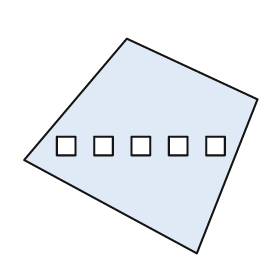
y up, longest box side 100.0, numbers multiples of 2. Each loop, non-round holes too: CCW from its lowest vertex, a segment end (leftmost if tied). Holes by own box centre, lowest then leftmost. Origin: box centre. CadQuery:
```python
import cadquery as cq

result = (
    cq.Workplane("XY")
    .moveTo(24.0, -46.0)
    .lineTo(50.0, 20.0)
    .lineTo(-6.0, 46.0)
    .lineTo(-50.0, -6.0)
    .close()
    .moveTo(-36.0, -4.0)
    .lineTo(-28.0, -4.0)
    .lineTo(-28.0, 4.0)
    .lineTo(-36.0, 4.0)
    .close()
    .moveTo(-20.0, -4.0)
    .lineTo(-12.0, -4.0)
    .lineTo(-12.0, 4.0)
    .lineTo(-20.0, 4.0)
    .close()
    .moveTo(-4.0, -4.0)
    .lineTo(4.0, -4.0)
    .lineTo(4.0, 4.0)
    .lineTo(-4.0, 4.0)
    .close()
    .moveTo(12.0, -4.0)
    .lineTo(20.0, -4.0)
    .lineTo(20.0, 4.0)
    .lineTo(12.0, 4.0)
    .close()
    .moveTo(28.0, -4.0)
    .lineTo(36.0, -4.0)
    .lineTo(36.0, 4.0)
    .lineTo(28.0, 4.0)
    .close()
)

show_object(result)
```